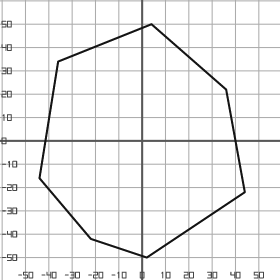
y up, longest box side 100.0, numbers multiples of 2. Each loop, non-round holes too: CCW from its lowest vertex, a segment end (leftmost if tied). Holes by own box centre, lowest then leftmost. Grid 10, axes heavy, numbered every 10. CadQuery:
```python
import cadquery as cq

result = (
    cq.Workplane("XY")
    .moveTo(2.0, -50.0)
    .lineTo(44.0, -22.0)
    .lineTo(36.0, 22.0)
    .lineTo(4.0, 50.0)
    .lineTo(-36.0, 34.0)
    .lineTo(-44.0, -16.0)
    .lineTo(-22.0, -42.0)
    .close()
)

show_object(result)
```